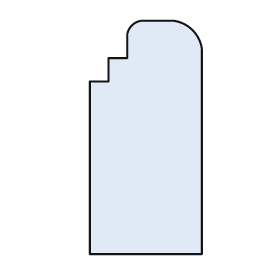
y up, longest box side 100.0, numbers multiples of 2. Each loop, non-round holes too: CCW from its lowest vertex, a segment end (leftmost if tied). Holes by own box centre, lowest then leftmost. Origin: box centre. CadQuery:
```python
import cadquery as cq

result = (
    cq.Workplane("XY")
    .moveTo(-24.0, -50.0)
    .lineTo(24.0, -50.0)
    .lineTo(24.0, 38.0)
    .threePointArc((20.0, 46.0), (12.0, 50.0))
    .lineTo(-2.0, 50.0)
    .threePointArc((-6.0, 48.0), (-8.0, 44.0))
    .lineTo(-8.0, 34.0)
    .lineTo(-16.0, 34.0)
    .lineTo(-16.0, 24.0)
    .lineTo(-24.0, 24.0)
    .close()
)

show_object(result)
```